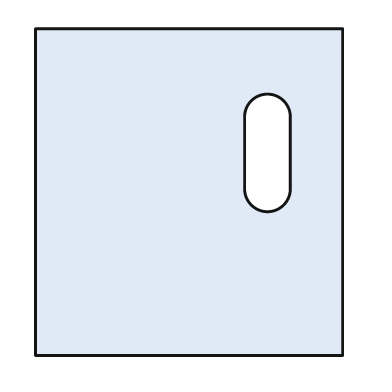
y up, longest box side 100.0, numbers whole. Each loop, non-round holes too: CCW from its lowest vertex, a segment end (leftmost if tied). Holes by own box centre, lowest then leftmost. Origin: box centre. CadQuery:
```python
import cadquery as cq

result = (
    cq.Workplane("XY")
    .moveTo(-47.0, -50.0)
    .lineTo(47.0, -50.0)
    .lineTo(47.0, 50.0)
    .lineTo(-47.0, 50.0)
    .close()
    .moveTo(17.0, 1.0)
    .threePointArc((24.0, -6.0), (31.0, 1.0))
    .lineTo(31.0, 23.0)
    .threePointArc((24.0, 30.0), (17.0, 23.0))
    .close()
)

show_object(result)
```